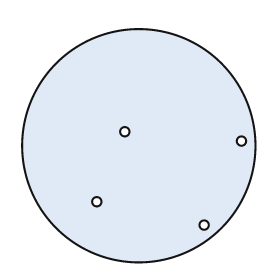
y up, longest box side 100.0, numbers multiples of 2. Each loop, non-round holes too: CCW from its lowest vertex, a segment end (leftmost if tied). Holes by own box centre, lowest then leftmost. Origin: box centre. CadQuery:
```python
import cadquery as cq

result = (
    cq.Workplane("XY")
    .moveTo(0.0, 0.0)
    .circle(50.0)
    .moveTo(28.0, -34.0)
    .circle(2.0)
    .moveTo(-18.0, -24.0)
    .circle(2.0)
    .moveTo(44.0, 2.0)
    .circle(2.0)
    .moveTo(-6.0, 6.0)
    .circle(2.0)
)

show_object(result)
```